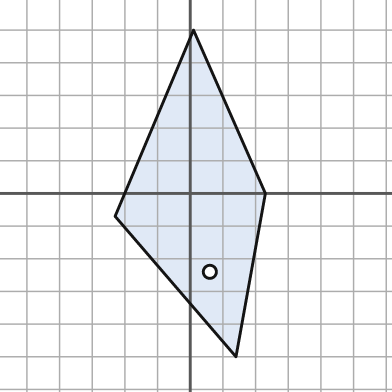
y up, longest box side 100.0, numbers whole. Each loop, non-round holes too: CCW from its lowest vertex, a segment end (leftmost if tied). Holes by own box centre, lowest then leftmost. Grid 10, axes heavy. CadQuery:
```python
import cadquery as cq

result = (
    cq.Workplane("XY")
    .moveTo(14.0, -50.0)
    .lineTo(23.0, 0.0)
    .lineTo(1.0, 50.0)
    .lineTo(-23.0, -7.0)
    .close()
    .moveTo(6.0, -24.0)
    .circle(2.0)
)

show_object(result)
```